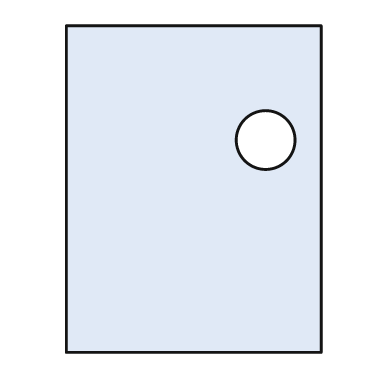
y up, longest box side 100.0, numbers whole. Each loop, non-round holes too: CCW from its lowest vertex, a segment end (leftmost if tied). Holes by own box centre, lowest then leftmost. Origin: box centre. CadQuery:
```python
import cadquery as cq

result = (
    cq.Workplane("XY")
    .moveTo(-39.0, -50.0)
    .lineTo(39.0, -50.0)
    .lineTo(39.0, 50.0)
    .lineTo(-39.0, 50.0)
    .close()
    .moveTo(22.0, 15.0)
    .circle(9.0)
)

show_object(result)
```